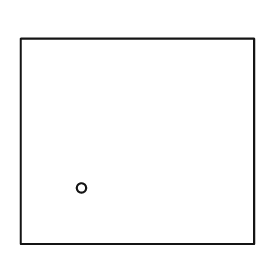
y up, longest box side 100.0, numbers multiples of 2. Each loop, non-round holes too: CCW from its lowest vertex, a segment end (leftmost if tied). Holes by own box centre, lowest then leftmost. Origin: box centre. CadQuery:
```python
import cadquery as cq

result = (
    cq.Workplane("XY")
    .moveTo(-50.0, -44.0)
    .lineTo(50.0, -44.0)
    .lineTo(50.0, 44.0)
    .lineTo(-50.0, 44.0)
    .close()
    .moveTo(-24.0, -20.0)
    .circle(2.0)
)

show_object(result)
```